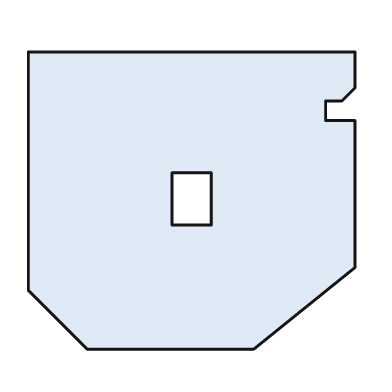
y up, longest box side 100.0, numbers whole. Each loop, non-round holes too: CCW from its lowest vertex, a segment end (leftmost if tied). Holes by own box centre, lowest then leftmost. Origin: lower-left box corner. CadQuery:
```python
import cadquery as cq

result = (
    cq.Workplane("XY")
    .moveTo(18.0, 0.0)
    .lineTo(69.0, 0.0)
    .lineTo(100.0, 25.0)
    .lineTo(100.0, 70.0)
    .lineTo(91.0, 70.0)
    .lineTo(91.0, 76.0)
    .lineTo(96.0, 76.0)
    .lineTo(100.0, 80.0)
    .lineTo(100.0, 91.0)
    .lineTo(0.0, 91.0)
    .lineTo(0.0, 18.0)
    .close()
    .moveTo(44.0, 38.0)
    .lineTo(56.0, 38.0)
    .lineTo(56.0, 54.0)
    .lineTo(44.0, 54.0)
    .close()
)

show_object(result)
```